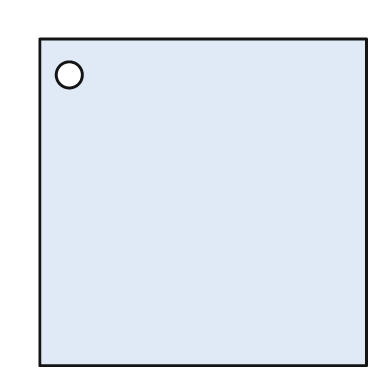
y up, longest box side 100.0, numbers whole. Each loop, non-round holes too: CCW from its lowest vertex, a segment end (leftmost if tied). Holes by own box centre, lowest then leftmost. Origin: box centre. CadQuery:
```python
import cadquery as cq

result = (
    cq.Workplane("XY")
    .moveTo(-50.0, -50.0)
    .lineTo(50.0, -50.0)
    .lineTo(50.0, 50.0)
    .lineTo(-50.0, 50.0)
    .close()
    .moveTo(-41.0, 39.0)
    .circle(4.0)
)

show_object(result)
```